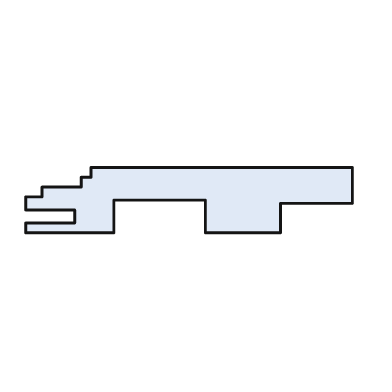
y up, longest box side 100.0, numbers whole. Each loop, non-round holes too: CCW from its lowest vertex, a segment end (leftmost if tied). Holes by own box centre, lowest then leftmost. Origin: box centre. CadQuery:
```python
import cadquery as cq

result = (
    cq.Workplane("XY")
    .moveTo(-50.0, -10.0)
    .lineTo(-23.0, -10.0)
    .lineTo(-23.0, 0.0)
    .lineTo(5.0, 0.0)
    .lineTo(5.0, -10.0)
    .lineTo(28.0, -10.0)
    .lineTo(28.0, -1.0)
    .lineTo(50.0, -1.0)
    .lineTo(50.0, 10.0)
    .lineTo(-30.0, 10.0)
    .lineTo(-30.0, 7.0)
    .lineTo(-33.0, 7.0)
    .lineTo(-33.0, 4.0)
    .lineTo(-45.0, 4.0)
    .lineTo(-45.0, 1.0)
    .lineTo(-50.0, 1.0)
    .lineTo(-50.0, -3.0)
    .lineTo(-35.0, -3.0)
    .lineTo(-35.0, -7.0)
    .lineTo(-50.0, -7.0)
    .close()
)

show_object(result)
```